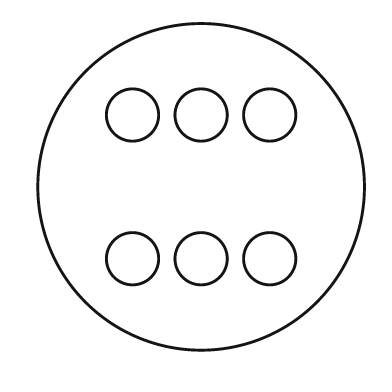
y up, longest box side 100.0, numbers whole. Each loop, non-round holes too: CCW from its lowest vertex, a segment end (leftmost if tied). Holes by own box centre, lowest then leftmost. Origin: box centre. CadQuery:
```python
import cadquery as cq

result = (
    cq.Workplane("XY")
    .moveTo(0.0, 0.0)
    .circle(50.0)
    .moveTo(-21.0, -22.0)
    .circle(8.0)
    .moveTo(0.0, -22.0)
    .circle(8.0)
    .moveTo(21.0, -22.0)
    .circle(8.0)
    .moveTo(-21.0, 22.0)
    .circle(8.0)
    .moveTo(0.0, 22.0)
    .circle(8.0)
    .moveTo(21.0, 22.0)
    .circle(8.0)
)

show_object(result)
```